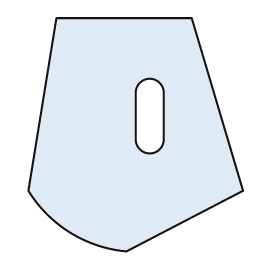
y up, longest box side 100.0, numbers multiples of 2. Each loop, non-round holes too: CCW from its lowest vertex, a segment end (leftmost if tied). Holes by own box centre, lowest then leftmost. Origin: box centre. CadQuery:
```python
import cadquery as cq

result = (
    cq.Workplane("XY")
    .moveTo(-4.0, -50.0)
    .lineTo(46.0, -24.0)
    .lineTo(24.0, 50.0)
    .lineTo(-34.0, 50.0)
    .lineTo(-46.0, -24.0)
    .threePointArc((-28.0, -42.0), (-4.0, -50.0))
    .close()
    .moveTo(0.0, -2.0)
    .threePointArc((6.0, -8.0), (12.0, -2.0))
    .lineTo(12.0, 18.0)
    .threePointArc((6.0, 24.0), (0.0, 18.0))
    .close()
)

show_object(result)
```